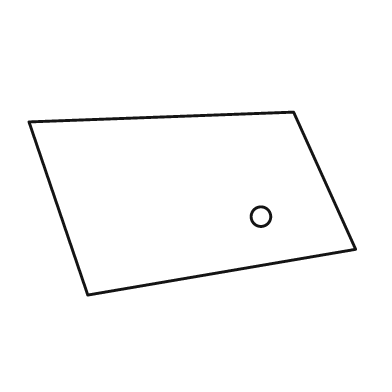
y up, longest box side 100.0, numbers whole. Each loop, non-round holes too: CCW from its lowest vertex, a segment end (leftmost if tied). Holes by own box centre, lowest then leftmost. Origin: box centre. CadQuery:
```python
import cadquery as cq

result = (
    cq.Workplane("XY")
    .moveTo(-32.0, -28.0)
    .lineTo(50.0, -14.0)
    .lineTo(31.0, 28.0)
    .lineTo(-50.0, 25.0)
    .close()
    .moveTo(21.0, -4.0)
    .circle(3.0)
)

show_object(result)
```